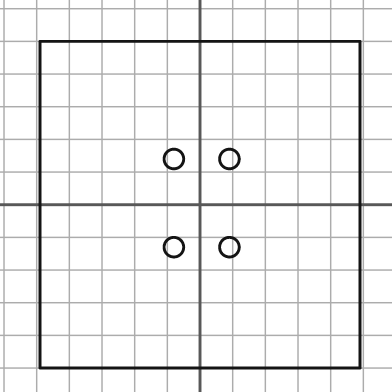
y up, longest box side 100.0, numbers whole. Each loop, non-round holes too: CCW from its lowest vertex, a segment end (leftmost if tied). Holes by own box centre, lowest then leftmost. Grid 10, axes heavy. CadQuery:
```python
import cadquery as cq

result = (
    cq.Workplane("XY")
    .moveTo(-49.0, -50.0)
    .lineTo(49.0, -50.0)
    .lineTo(49.0, 50.0)
    .lineTo(-49.0, 50.0)
    .close()
    .moveTo(-8.0, -13.0)
    .circle(3.0)
    .moveTo(9.0, -13.0)
    .circle(3.0)
    .moveTo(-8.0, 14.0)
    .circle(3.0)
    .moveTo(9.0, 14.0)
    .circle(3.0)
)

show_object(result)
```